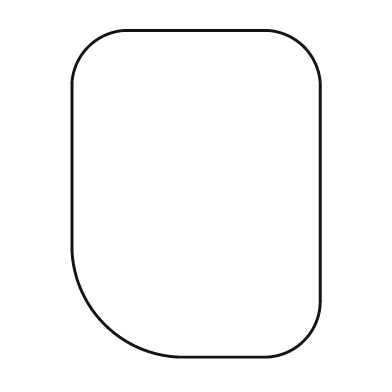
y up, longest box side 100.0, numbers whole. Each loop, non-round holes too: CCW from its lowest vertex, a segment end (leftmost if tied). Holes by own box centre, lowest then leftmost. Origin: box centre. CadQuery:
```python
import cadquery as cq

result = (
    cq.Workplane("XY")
    .moveTo(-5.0, -50.0)
    .lineTo(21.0, -50.0)
    .threePointArc((33.0, -45.0), (38.0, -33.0))
    .lineTo(38.0, 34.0)
    .threePointArc((33.0, 45.0), (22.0, 50.0))
    .lineTo(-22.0, 50.0)
    .threePointArc((-33.0, 45.0), (-38.0, 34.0))
    .lineTo(-38.0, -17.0)
    .threePointArc((-28.0, -40.0), (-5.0, -50.0))
    .close()
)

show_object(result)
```